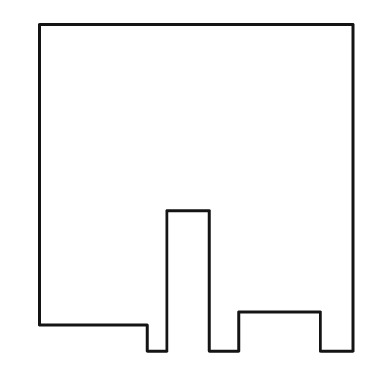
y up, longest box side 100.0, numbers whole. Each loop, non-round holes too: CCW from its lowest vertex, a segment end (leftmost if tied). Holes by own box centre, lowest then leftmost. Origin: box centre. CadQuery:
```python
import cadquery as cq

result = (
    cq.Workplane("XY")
    .moveTo(-15.0, -50.0)
    .lineTo(-9.0, -50.0)
    .lineTo(-9.0, -7.0)
    .lineTo(4.0, -7.0)
    .lineTo(4.0, -50.0)
    .lineTo(13.0, -50.0)
    .lineTo(13.0, -38.0)
    .lineTo(38.0, -38.0)
    .lineTo(38.0, -50.0)
    .lineTo(48.0, -50.0)
    .lineTo(48.0, 50.0)
    .lineTo(-48.0, 50.0)
    .lineTo(-48.0, -42.0)
    .lineTo(-15.0, -42.0)
    .close()
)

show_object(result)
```